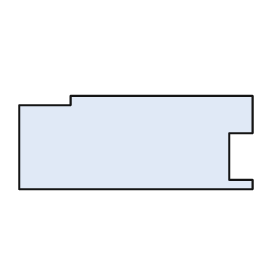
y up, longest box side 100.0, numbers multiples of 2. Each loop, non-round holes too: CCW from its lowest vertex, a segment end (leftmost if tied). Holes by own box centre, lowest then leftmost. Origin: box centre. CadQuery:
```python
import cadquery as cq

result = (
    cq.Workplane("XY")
    .moveTo(-50.0, -20.0)
    .lineTo(50.0, -20.0)
    .lineTo(50.0, -16.0)
    .lineTo(40.0, -16.0)
    .lineTo(40.0, 4.0)
    .lineTo(50.0, 4.0)
    .lineTo(50.0, 20.0)
    .lineTo(-28.0, 20.0)
    .lineTo(-28.0, 16.0)
    .lineTo(-50.0, 16.0)
    .close()
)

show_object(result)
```